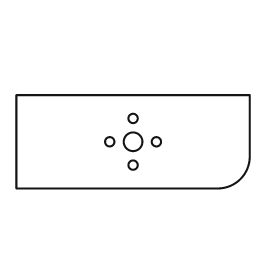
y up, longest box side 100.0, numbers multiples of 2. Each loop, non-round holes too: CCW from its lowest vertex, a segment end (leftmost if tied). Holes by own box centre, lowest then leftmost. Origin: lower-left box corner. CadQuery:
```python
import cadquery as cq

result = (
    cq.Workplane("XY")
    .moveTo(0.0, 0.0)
    .lineTo(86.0, 0.0)
    .threePointArc((96.0, 4.0), (100.0, 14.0))
    .lineTo(100.0, 40.0)
    .lineTo(0.0, 40.0)
    .close()
    .moveTo(50.0, 10.0)
    .circle(2.0)
    .moveTo(40.0, 20.0)
    .circle(2.0)
    .moveTo(50.0, 20.0)
    .circle(4.0)
    .moveTo(60.0, 20.0)
    .circle(2.0)
    .moveTo(50.0, 30.0)
    .circle(2.0)
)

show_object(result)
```